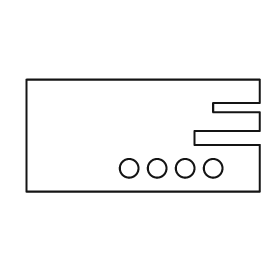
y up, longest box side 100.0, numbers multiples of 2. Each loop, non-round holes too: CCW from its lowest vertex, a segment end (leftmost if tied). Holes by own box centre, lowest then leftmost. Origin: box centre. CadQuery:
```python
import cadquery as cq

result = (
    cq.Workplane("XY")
    .moveTo(-50.0, -24.0)
    .lineTo(50.0, -24.0)
    .lineTo(50.0, -4.0)
    .lineTo(22.0, -4.0)
    .lineTo(22.0, 2.0)
    .lineTo(50.0, 2.0)
    .lineTo(50.0, 10.0)
    .lineTo(30.0, 10.0)
    .lineTo(30.0, 14.0)
    .lineTo(50.0, 14.0)
    .lineTo(50.0, 24.0)
    .lineTo(-50.0, 24.0)
    .close()
    .moveTo(-6.0, -14.0)
    .circle(4.0)
    .moveTo(6.0, -14.0)
    .circle(4.0)
    .moveTo(18.0, -14.0)
    .circle(4.0)
    .moveTo(30.0, -14.0)
    .circle(4.0)
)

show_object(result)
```